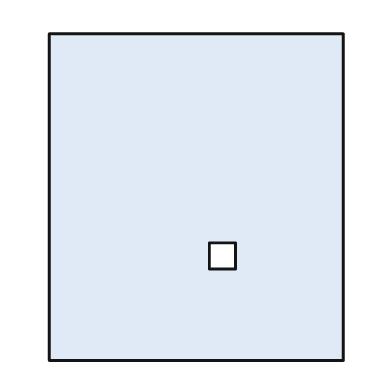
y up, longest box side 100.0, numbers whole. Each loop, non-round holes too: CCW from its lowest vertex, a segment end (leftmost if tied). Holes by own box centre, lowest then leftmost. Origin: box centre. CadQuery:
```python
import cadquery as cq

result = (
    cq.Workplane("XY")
    .moveTo(-45.0, -50.0)
    .lineTo(45.0, -50.0)
    .lineTo(45.0, 50.0)
    .lineTo(-45.0, 50.0)
    .close()
    .moveTo(4.0, -22.0)
    .lineTo(12.0, -22.0)
    .lineTo(12.0, -14.0)
    .lineTo(4.0, -14.0)
    .close()
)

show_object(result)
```